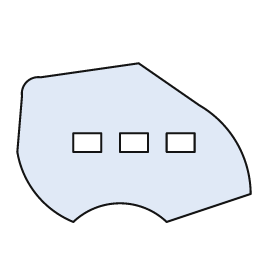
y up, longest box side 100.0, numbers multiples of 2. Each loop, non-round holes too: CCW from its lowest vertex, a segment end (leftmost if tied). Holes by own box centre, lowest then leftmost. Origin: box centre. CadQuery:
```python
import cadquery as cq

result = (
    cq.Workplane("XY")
    .moveTo(-26.0, -34.0)
    .threePointArc((-6.0, -26.0), (14.0, -34.0))
    .lineTo(50.0, -22.0)
    .threePointArc((44.0, 0.0), (28.0, 16.0))
    .lineTo(2.0, 34.0)
    .lineTo(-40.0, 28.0)
    .threePointArc((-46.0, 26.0), (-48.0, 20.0))
    .lineTo(-50.0, -4.0)
    .threePointArc((-42.0, -22.0), (-26.0, -34.0))
    .close()
    .moveTo(-26.0, -4.0)
    .lineTo(-14.0, -4.0)
    .lineTo(-14.0, 4.0)
    .lineTo(-26.0, 4.0)
    .close()
    .moveTo(-6.0, -4.0)
    .lineTo(6.0, -4.0)
    .lineTo(6.0, 4.0)
    .lineTo(-6.0, 4.0)
    .close()
    .moveTo(14.0, -4.0)
    .lineTo(26.0, -4.0)
    .lineTo(26.0, 4.0)
    .lineTo(14.0, 4.0)
    .close()
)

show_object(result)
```